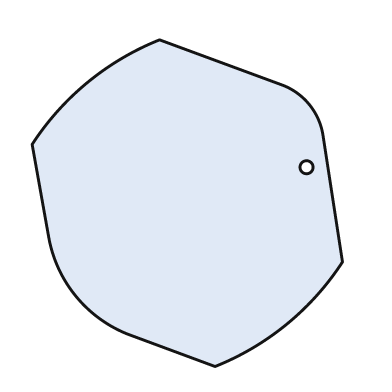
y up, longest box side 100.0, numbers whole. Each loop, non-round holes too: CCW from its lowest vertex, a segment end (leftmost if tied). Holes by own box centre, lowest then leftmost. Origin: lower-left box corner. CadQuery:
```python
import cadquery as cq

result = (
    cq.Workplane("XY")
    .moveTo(56.0, 0.0)
    .threePointArc((78.0, 13.0), (95.0, 32.0))
    .lineTo(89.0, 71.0)
    .threePointArc((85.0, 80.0), (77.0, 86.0))
    .lineTo(39.0, 100.0)
    .threePointArc((17.0, 87.0), (0.0, 68.0))
    .lineTo(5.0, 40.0)
    .threePointArc((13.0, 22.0), (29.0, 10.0))
    .close()
    .moveTo(84.0, 61.0)
    .circle(2.0)
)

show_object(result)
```